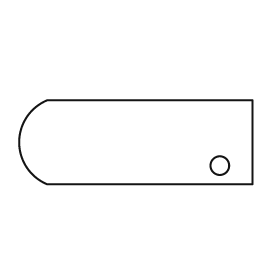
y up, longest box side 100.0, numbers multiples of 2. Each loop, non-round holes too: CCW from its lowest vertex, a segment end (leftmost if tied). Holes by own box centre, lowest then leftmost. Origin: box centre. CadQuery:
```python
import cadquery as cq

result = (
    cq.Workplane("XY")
    .moveTo(-38.0, -18.0)
    .lineTo(50.0, -18.0)
    .lineTo(50.0, 18.0)
    .lineTo(-38.0, 18.0)
    .threePointArc((-50.0, 0.0), (-38.0, -18.0))
    .close()
    .moveTo(36.0, -10.0)
    .circle(4.0)
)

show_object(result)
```